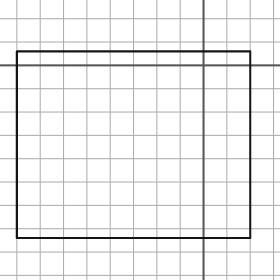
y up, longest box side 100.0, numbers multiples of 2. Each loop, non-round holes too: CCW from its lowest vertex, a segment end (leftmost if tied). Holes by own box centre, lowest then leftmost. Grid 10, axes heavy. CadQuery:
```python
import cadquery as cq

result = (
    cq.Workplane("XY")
    .moveTo(-80.0, -74.0)
    .lineTo(20.0, -74.0)
    .lineTo(20.0, 6.0)
    .lineTo(-80.0, 6.0)
    .close()
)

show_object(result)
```